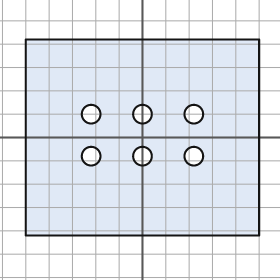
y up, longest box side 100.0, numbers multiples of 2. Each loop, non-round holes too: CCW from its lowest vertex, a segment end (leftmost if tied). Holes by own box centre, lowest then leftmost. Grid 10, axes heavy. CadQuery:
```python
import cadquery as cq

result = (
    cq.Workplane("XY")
    .moveTo(-50.0, -42.0)
    .lineTo(50.0, -42.0)
    .lineTo(50.0, 42.0)
    .lineTo(-50.0, 42.0)
    .close()
    .moveTo(-22.0, -8.0)
    .circle(4.0)
    .moveTo(0.0, -8.0)
    .circle(4.0)
    .moveTo(22.0, -8.0)
    .circle(4.0)
    .moveTo(-22.0, 10.0)
    .circle(4.0)
    .moveTo(0.0, 10.0)
    .circle(4.0)
    .moveTo(22.0, 10.0)
    .circle(4.0)
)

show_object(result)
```